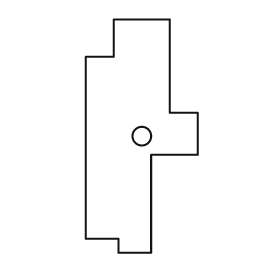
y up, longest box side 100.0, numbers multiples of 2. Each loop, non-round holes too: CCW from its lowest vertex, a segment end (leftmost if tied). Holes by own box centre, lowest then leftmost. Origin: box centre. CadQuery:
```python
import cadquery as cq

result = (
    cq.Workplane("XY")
    .moveTo(-10.0, -50.0)
    .lineTo(4.0, -50.0)
    .lineTo(4.0, -8.0)
    .lineTo(24.0, -8.0)
    .lineTo(24.0, 10.0)
    .lineTo(12.0, 10.0)
    .lineTo(12.0, 50.0)
    .lineTo(-12.0, 50.0)
    .lineTo(-12.0, 34.0)
    .lineTo(-24.0, 34.0)
    .lineTo(-24.0, -44.0)
    .lineTo(-10.0, -44.0)
    .close()
    .moveTo(0.0, 0.0)
    .circle(4.0)
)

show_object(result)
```